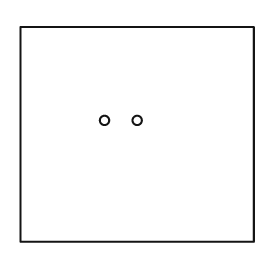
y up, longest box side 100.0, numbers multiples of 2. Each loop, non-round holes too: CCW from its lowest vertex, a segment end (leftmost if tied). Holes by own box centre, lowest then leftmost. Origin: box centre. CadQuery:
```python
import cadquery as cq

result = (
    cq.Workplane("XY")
    .moveTo(-50.0, -46.0)
    .lineTo(50.0, -46.0)
    .lineTo(50.0, 46.0)
    .lineTo(-50.0, 46.0)
    .close()
    .moveTo(-14.0, 6.0)
    .circle(2.0)
    .moveTo(0.0, 6.0)
    .circle(2.0)
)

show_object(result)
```